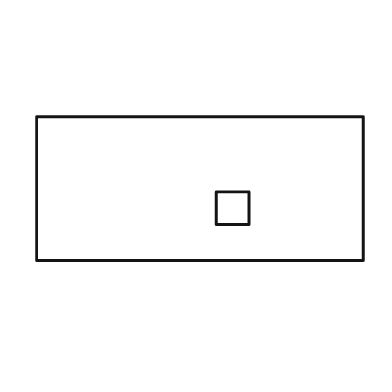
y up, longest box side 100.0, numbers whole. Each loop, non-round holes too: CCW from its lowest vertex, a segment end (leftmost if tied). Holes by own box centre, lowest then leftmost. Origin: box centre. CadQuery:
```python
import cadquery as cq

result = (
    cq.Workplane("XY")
    .moveTo(-50.0, -22.0)
    .lineTo(50.0, -22.0)
    .lineTo(50.0, 22.0)
    .lineTo(-50.0, 22.0)
    .close()
    .moveTo(5.0, -11.0)
    .lineTo(15.0, -11.0)
    .lineTo(15.0, -1.0)
    .lineTo(5.0, -1.0)
    .close()
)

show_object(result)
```